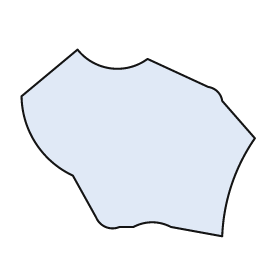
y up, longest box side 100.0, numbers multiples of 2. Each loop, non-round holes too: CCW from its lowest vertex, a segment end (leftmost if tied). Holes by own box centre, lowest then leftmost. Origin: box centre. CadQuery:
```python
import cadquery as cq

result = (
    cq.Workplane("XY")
    .moveTo(36.0, -40.0)
    .threePointArc((40.0, -18.0), (50.0, 2.0))
    .lineTo(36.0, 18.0)
    .threePointArc((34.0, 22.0), (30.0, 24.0))
    .lineTo(4.0, 36.0)
    .threePointArc((-12.0, 32.0), (-26.0, 40.0))
    .lineTo(-50.0, 20.0)
    .threePointArc((-44.0, 0.0), (-28.0, -14.0))
    .lineTo(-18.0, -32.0)
    .threePointArc((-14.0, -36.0), (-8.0, -36.0))
    .lineTo(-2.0, -36.0)
    .threePointArc((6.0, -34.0), (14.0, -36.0))
    .close()
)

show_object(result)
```